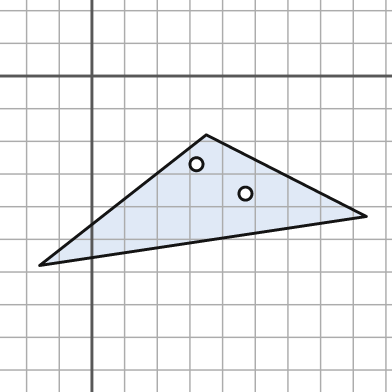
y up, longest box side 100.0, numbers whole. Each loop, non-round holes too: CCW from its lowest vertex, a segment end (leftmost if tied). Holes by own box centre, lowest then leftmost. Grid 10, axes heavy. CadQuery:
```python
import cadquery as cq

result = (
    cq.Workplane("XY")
    .moveTo(-16.0, -58.0)
    .lineTo(84.0, -43.0)
    .lineTo(35.0, -18.0)
    .close()
    .moveTo(47.0, -36.0)
    .circle(2.0)
    .moveTo(32.0, -27.0)
    .circle(2.0)
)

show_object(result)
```